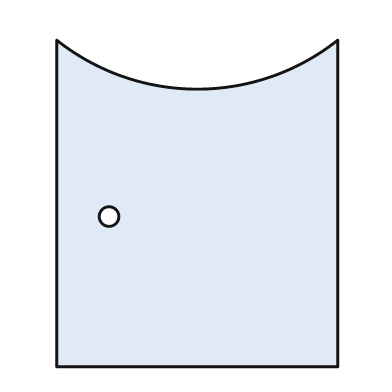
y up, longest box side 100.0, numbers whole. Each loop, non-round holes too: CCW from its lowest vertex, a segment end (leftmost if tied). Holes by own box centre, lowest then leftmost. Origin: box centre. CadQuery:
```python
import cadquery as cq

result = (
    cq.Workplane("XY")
    .moveTo(-43.0, -50.0)
    .lineTo(43.0, -50.0)
    .lineTo(43.0, 50.0)
    .threePointArc((0.0, 35.0), (-43.0, 50.0))
    .close()
    .moveTo(-27.0, -4.0)
    .circle(3.0)
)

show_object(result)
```